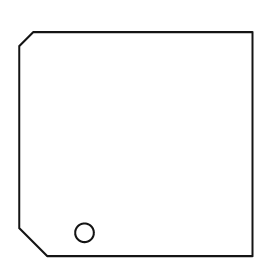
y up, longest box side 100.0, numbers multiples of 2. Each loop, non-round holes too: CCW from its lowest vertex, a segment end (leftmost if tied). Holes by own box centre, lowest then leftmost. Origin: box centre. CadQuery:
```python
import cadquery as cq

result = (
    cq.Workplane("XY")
    .moveTo(-38.0, -48.0)
    .lineTo(50.0, -48.0)
    .lineTo(50.0, 48.0)
    .lineTo(-44.0, 48.0)
    .lineTo(-50.0, 42.0)
    .lineTo(-50.0, -36.0)
    .close()
    .moveTo(-22.0, -38.0)
    .circle(4.0)
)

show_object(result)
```